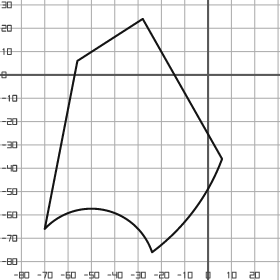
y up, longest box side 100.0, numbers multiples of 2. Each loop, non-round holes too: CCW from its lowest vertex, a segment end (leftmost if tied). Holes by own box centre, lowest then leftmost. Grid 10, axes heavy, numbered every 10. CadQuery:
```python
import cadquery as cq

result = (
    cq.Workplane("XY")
    .moveTo(-24.0, -76.0)
    .threePointArc((-6.0, -58.0), (6.0, -36.0))
    .lineTo(-28.0, 24.0)
    .lineTo(-56.0, 6.0)
    .lineTo(-70.0, -66.0)
    .threePointArc((-44.0, -58.0), (-24.0, -76.0))
    .close()
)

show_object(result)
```